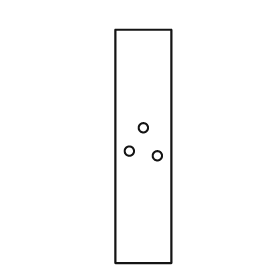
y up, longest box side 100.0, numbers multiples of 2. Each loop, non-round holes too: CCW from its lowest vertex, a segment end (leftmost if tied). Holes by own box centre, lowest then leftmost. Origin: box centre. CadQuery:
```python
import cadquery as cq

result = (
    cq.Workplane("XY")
    .moveTo(-12.0, -50.0)
    .lineTo(12.0, -50.0)
    .lineTo(12.0, 50.0)
    .lineTo(-12.0, 50.0)
    .close()
    .moveTo(6.0, -4.0)
    .circle(2.0)
    .moveTo(-6.0, -2.0)
    .circle(2.0)
    .moveTo(0.0, 8.0)
    .circle(2.0)
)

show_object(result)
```